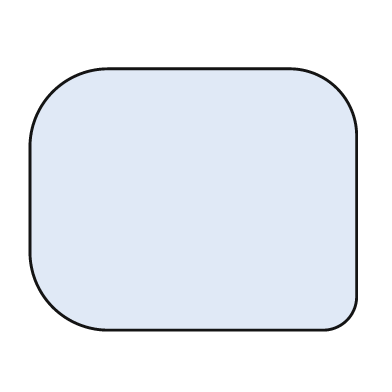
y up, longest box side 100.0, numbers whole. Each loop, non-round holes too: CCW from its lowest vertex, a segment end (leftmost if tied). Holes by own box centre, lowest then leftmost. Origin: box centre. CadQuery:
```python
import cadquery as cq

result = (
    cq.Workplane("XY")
    .moveTo(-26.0, -40.0)
    .lineTo(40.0, -40.0)
    .threePointArc((47.0, -37.0), (50.0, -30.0))
    .lineTo(50.0, 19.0)
    .threePointArc((44.0, 34.0), (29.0, 40.0))
    .lineTo(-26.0, 40.0)
    .threePointArc((-43.0, 33.0), (-50.0, 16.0))
    .lineTo(-50.0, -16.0)
    .threePointArc((-43.0, -33.0), (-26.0, -40.0))
    .close()
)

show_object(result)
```